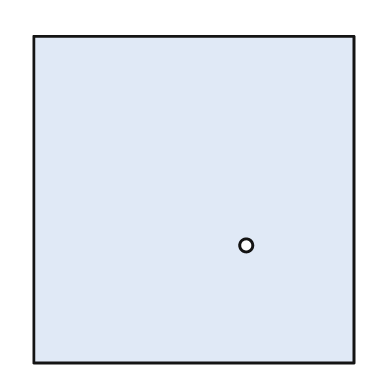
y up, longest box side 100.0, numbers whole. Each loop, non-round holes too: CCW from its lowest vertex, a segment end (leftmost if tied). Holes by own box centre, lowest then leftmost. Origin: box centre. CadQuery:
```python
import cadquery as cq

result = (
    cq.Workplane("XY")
    .moveTo(-49.0, -50.0)
    .lineTo(49.0, -50.0)
    .lineTo(49.0, 50.0)
    .lineTo(-49.0, 50.0)
    .close()
    .moveTo(16.0, -14.0)
    .circle(2.0)
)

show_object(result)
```